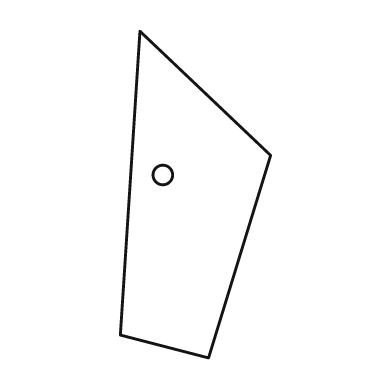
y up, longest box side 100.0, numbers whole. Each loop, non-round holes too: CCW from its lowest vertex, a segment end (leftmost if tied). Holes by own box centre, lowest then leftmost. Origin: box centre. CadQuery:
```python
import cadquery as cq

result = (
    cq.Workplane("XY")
    .moveTo(4.0, -50.0)
    .lineTo(23.0, 12.0)
    .lineTo(-17.0, 50.0)
    .lineTo(-23.0, -43.0)
    .close()
    .moveTo(-10.0, 6.0)
    .circle(3.0)
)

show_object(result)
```